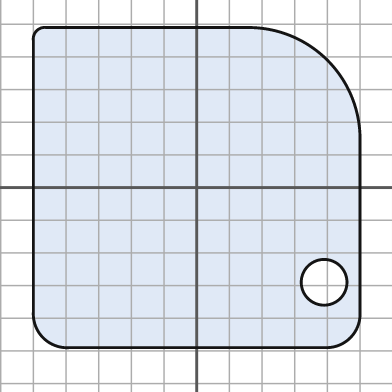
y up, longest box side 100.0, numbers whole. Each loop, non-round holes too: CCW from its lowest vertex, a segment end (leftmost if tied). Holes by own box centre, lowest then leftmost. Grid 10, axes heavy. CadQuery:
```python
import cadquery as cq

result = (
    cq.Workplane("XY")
    .moveTo(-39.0, -49.0)
    .lineTo(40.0, -49.0)
    .threePointArc((47.0, -46.0), (50.0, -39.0))
    .lineTo(50.0, 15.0)
    .threePointArc((40.0, 39.0), (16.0, 49.0))
    .lineTo(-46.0, 49.0)
    .threePointArc((-49.0, 48.0), (-50.0, 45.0))
    .lineTo(-50.0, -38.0)
    .threePointArc((-47.0, -46.0), (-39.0, -49.0))
    .close()
    .moveTo(39.0, -29.0)
    .circle(7.0)
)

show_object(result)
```